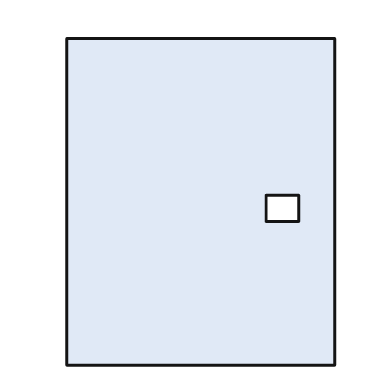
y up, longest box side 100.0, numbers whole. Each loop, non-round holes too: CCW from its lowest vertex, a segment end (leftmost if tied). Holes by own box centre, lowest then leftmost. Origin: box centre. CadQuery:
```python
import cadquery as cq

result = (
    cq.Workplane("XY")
    .moveTo(-41.0, -50.0)
    .lineTo(41.0, -50.0)
    .lineTo(41.0, 50.0)
    .lineTo(-41.0, 50.0)
    .close()
    .moveTo(20.0, -6.0)
    .lineTo(30.0, -6.0)
    .lineTo(30.0, 2.0)
    .lineTo(20.0, 2.0)
    .close()
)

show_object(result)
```